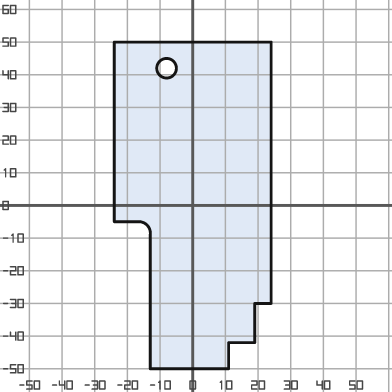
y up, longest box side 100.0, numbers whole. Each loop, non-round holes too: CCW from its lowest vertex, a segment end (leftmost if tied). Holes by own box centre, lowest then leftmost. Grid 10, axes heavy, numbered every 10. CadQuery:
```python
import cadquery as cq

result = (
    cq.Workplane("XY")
    .moveTo(-13.0, -50.0)
    .lineTo(11.0, -50.0)
    .lineTo(11.0, -42.0)
    .lineTo(19.0, -42.0)
    .lineTo(19.0, -30.0)
    .lineTo(24.0, -30.0)
    .lineTo(24.0, 50.0)
    .lineTo(-24.0, 50.0)
    .lineTo(-24.0, -5.0)
    .lineTo(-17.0, -5.0)
    .threePointArc((-14.0, -6.0), (-13.0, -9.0))
    .close()
    .moveTo(-8.0, 42.0)
    .circle(3.0)
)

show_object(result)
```